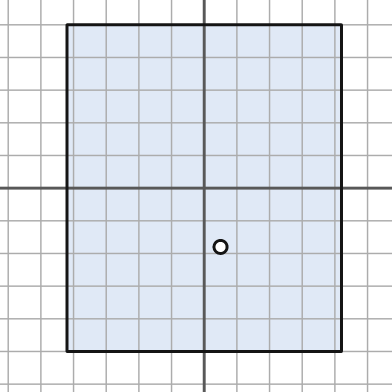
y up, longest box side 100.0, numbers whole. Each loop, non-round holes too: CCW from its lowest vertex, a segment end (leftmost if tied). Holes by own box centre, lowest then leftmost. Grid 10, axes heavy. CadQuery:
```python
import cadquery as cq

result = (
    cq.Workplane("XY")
    .moveTo(-42.0, -50.0)
    .lineTo(42.0, -50.0)
    .lineTo(42.0, 50.0)
    .lineTo(-42.0, 50.0)
    .close()
    .moveTo(5.0, -18.0)
    .circle(2.0)
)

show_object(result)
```